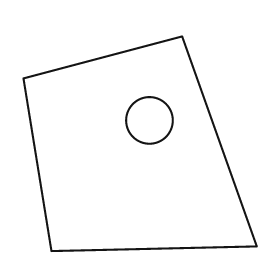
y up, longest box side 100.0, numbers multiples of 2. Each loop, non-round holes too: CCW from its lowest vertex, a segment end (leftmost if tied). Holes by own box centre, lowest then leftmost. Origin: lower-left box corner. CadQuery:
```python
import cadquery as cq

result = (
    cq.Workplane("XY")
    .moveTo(12.0, 0.0)
    .lineTo(100.0, 2.0)
    .lineTo(68.0, 92.0)
    .lineTo(0.0, 74.0)
    .close()
    .moveTo(54.0, 56.0)
    .circle(10.0)
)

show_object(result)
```